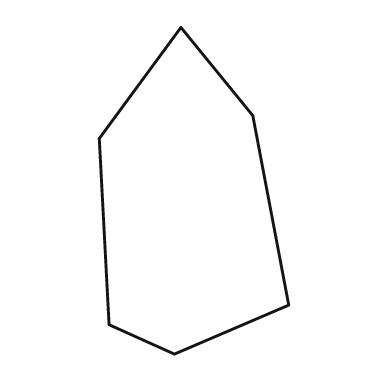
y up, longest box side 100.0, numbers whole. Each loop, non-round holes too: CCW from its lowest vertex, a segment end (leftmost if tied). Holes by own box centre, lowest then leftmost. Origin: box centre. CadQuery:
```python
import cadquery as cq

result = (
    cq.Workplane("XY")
    .moveTo(-6.0, -50.0)
    .lineTo(29.0, -35.0)
    .lineTo(18.0, 23.0)
    .lineTo(-4.0, 50.0)
    .lineTo(-29.0, 16.0)
    .lineTo(-26.0, -41.0)
    .close()
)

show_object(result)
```